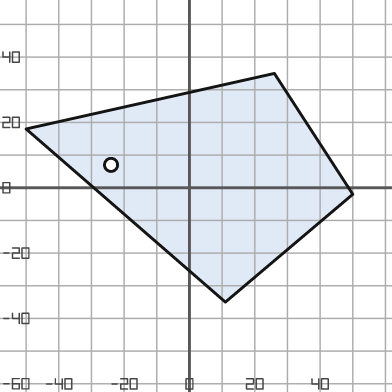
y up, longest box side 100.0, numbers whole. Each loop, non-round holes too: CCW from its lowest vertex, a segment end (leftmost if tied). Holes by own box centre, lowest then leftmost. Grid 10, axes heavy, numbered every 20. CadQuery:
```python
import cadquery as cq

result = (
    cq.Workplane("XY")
    .moveTo(11.0, -35.0)
    .lineTo(50.0, -2.0)
    .lineTo(26.0, 35.0)
    .lineTo(-50.0, 18.0)
    .close()
    .moveTo(-24.0, 7.0)
    .circle(2.0)
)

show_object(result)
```